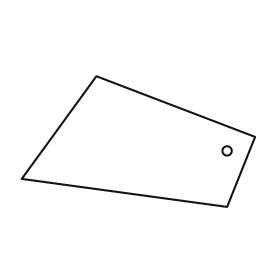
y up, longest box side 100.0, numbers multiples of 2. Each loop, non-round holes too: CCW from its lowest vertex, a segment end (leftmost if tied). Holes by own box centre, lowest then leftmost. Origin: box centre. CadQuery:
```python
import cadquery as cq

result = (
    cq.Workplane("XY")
    .moveTo(38.0, -28.0)
    .lineTo(50.0, 2.0)
    .lineTo(-18.0, 28.0)
    .lineTo(-50.0, -16.0)
    .close()
    .moveTo(38.0, -4.0)
    .circle(2.0)
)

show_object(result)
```